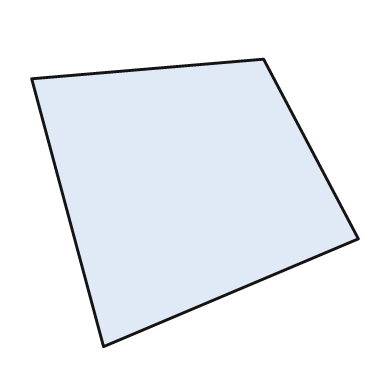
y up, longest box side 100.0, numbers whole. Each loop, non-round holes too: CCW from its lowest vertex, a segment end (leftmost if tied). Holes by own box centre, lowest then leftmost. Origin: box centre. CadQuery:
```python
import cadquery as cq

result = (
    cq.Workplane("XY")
    .moveTo(-28.0, -44.0)
    .lineTo(50.0, -11.0)
    .lineTo(21.0, 44.0)
    .lineTo(-50.0, 38.0)
    .close()
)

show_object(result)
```